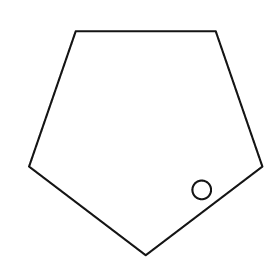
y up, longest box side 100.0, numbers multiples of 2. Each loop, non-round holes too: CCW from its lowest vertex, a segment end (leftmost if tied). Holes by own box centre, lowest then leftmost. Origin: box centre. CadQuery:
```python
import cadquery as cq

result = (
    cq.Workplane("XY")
    .moveTo(0.0, -48.0)
    .lineTo(50.0, -10.0)
    .lineTo(30.0, 48.0)
    .lineTo(-30.0, 48.0)
    .lineTo(-50.0, -10.0)
    .close()
    .moveTo(24.0, -20.0)
    .circle(4.0)
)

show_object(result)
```